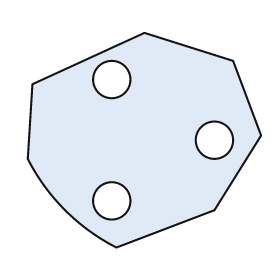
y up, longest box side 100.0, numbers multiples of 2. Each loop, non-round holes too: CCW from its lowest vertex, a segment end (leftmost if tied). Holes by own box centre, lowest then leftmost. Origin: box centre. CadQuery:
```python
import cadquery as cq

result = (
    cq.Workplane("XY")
    .moveTo(-12.0, -46.0)
    .lineTo(30.0, -30.0)
    .lineTo(50.0, 2.0)
    .lineTo(38.0, 34.0)
    .lineTo(0.0, 46.0)
    .lineTo(-48.0, 24.0)
    .lineTo(-50.0, -8.0)
    .threePointArc((-34.0, -30.0), (-12.0, -46.0))
    .close()
    .moveTo(-14.0, -26.0)
    .circle(8.0)
    .moveTo(30.0, 0.0)
    .circle(8.0)
    .moveTo(-14.0, 26.0)
    .circle(8.0)
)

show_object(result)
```